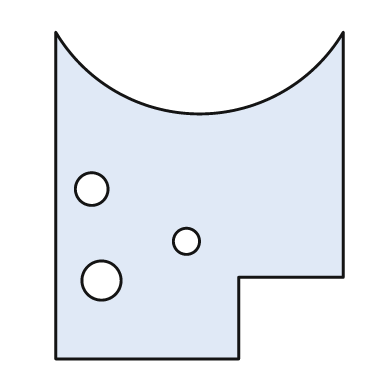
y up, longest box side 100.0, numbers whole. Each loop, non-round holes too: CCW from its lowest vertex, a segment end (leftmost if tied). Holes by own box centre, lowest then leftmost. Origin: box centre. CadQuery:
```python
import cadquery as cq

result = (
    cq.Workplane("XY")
    .moveTo(-44.0, -50.0)
    .lineTo(12.0, -50.0)
    .lineTo(12.0, -25.0)
    .lineTo(44.0, -25.0)
    .lineTo(44.0, 50.0)
    .threePointArc((0.0, 25.0), (-44.0, 50.0))
    .close()
    .moveTo(-30.0, -26.0)
    .circle(6.0)
    .moveTo(-4.0, -14.0)
    .circle(4.0)
    .moveTo(-33.0, 2.0)
    .circle(5.0)
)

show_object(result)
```